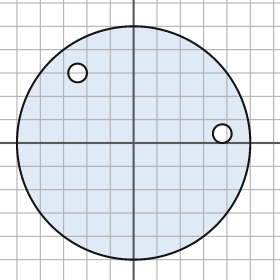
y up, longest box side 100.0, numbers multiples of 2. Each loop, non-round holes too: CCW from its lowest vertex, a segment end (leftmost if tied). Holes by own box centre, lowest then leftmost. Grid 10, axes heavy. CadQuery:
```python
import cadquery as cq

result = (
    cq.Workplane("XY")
    .moveTo(0.0, 0.0)
    .circle(50.0)
    .moveTo(38.0, 4.0)
    .circle(4.0)
    .moveTo(-24.0, 30.0)
    .circle(4.0)
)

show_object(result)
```